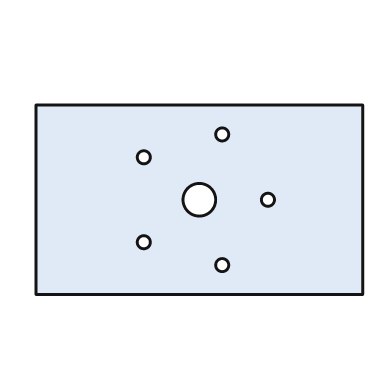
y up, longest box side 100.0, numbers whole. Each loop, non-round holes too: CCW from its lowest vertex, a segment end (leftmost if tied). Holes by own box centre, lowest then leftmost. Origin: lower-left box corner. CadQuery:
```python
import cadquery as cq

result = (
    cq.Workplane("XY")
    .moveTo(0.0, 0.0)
    .lineTo(100.0, 0.0)
    .lineTo(100.0, 58.0)
    .lineTo(0.0, 58.0)
    .close()
    .moveTo(57.0, 9.0)
    .circle(2.0)
    .moveTo(33.0, 16.0)
    .circle(2.0)
    .moveTo(50.0, 29.0)
    .circle(5.0)
    .moveTo(71.0, 29.0)
    .circle(2.0)
    .moveTo(33.0, 42.0)
    .circle(2.0)
    .moveTo(57.0, 49.0)
    .circle(2.0)
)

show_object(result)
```